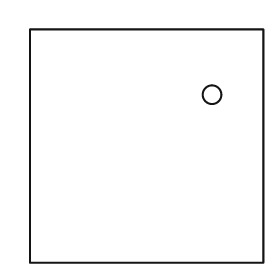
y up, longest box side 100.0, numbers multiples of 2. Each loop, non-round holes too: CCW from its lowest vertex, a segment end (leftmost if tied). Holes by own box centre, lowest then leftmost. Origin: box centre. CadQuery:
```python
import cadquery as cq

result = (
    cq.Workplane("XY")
    .moveTo(-50.0, -50.0)
    .lineTo(50.0, -50.0)
    .lineTo(50.0, 50.0)
    .lineTo(-50.0, 50.0)
    .close()
    .moveTo(28.0, 22.0)
    .circle(4.0)
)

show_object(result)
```